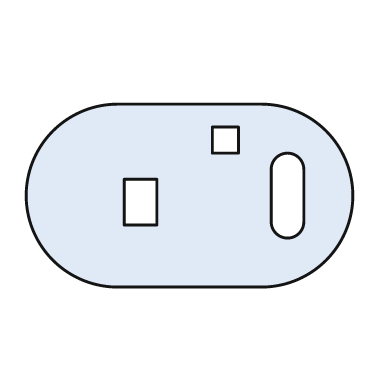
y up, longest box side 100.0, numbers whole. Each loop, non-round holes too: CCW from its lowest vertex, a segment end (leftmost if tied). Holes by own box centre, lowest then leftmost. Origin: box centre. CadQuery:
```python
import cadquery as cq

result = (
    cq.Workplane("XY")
    .moveTo(-22.0, -28.0)
    .lineTo(22.0, -28.0)
    .threePointArc((50.0, 0.0), (22.0, 28.0))
    .lineTo(-22.0, 28.0)
    .threePointArc((-50.0, 0.0), (-22.0, -28.0))
    .close()
    .moveTo(-20.0, -9.0)
    .lineTo(-10.0, -9.0)
    .lineTo(-10.0, 5.0)
    .lineTo(-20.0, 5.0)
    .close()
    .moveTo(25.0, -8.0)
    .threePointArc((30.0, -13.0), (35.0, -8.0))
    .lineTo(35.0, 8.0)
    .threePointArc((30.0, 13.0), (25.0, 8.0))
    .close()
    .moveTo(7.0, 13.0)
    .lineTo(15.0, 13.0)
    .lineTo(15.0, 21.0)
    .lineTo(7.0, 21.0)
    .close()
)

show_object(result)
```